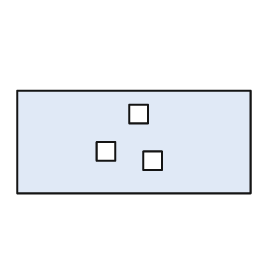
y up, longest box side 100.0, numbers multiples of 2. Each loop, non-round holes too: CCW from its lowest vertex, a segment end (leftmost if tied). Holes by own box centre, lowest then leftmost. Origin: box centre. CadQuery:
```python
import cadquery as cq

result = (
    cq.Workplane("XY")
    .moveTo(-50.0, -22.0)
    .lineTo(50.0, -22.0)
    .lineTo(50.0, 22.0)
    .lineTo(-50.0, 22.0)
    .close()
    .moveTo(4.0, -12.0)
    .lineTo(12.0, -12.0)
    .lineTo(12.0, -4.0)
    .lineTo(4.0, -4.0)
    .close()
    .moveTo(-16.0, -8.0)
    .lineTo(-8.0, -8.0)
    .lineTo(-8.0, 0.0)
    .lineTo(-16.0, 0.0)
    .close()
    .moveTo(-2.0, 8.0)
    .lineTo(6.0, 8.0)
    .lineTo(6.0, 16.0)
    .lineTo(-2.0, 16.0)
    .close()
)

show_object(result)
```